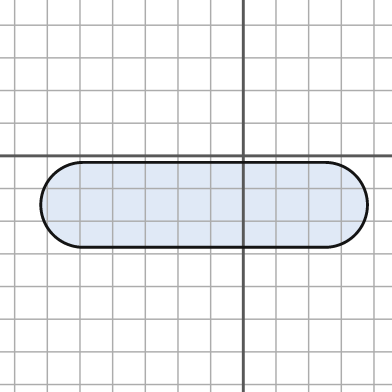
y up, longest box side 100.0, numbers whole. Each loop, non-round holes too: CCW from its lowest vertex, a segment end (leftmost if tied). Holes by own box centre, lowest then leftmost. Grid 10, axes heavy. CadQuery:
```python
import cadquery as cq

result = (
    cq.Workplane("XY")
    .moveTo(-49.0, -28.0)
    .lineTo(25.0, -28.0)
    .threePointArc((38.0, -15.0), (25.0, -2.0))
    .lineTo(-49.0, -2.0)
    .threePointArc((-62.0, -15.0), (-49.0, -28.0))
    .close()
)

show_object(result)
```